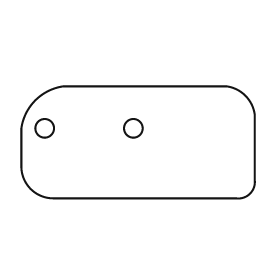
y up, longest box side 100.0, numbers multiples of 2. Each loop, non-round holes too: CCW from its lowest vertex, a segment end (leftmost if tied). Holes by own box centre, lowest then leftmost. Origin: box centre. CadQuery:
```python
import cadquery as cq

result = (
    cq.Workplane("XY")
    .moveTo(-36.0, -24.0)
    .lineTo(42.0, -24.0)
    .threePointArc((48.0, -22.0), (50.0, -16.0))
    .lineTo(50.0, 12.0)
    .threePointArc((46.0, 20.0), (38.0, 24.0))
    .lineTo(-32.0, 24.0)
    .threePointArc((-44.0, 18.0), (-50.0, 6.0))
    .lineTo(-50.0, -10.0)
    .threePointArc((-46.0, -20.0), (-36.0, -24.0))
    .close()
    .moveTo(-40.0, 6.0)
    .circle(4.0)
    .moveTo(-2.0, 6.0)
    .circle(4.0)
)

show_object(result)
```